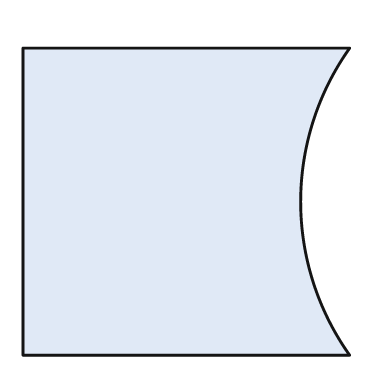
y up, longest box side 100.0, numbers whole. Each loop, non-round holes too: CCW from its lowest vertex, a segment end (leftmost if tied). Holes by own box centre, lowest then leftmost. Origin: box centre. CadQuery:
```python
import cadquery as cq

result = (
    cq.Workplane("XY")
    .moveTo(-50.0, -47.0)
    .lineTo(50.0, -47.0)
    .threePointArc((35.0, 0.0), (50.0, 47.0))
    .lineTo(-50.0, 47.0)
    .close()
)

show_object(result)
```